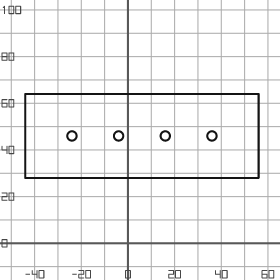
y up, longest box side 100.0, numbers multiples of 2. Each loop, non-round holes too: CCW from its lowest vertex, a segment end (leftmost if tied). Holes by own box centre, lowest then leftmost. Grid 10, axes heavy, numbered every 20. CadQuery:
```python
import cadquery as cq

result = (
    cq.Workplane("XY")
    .moveTo(-44.0, 28.0)
    .lineTo(56.0, 28.0)
    .lineTo(56.0, 64.0)
    .lineTo(-44.0, 64.0)
    .close()
    .moveTo(-24.0, 46.0)
    .circle(2.0)
    .moveTo(-4.0, 46.0)
    .circle(2.0)
    .moveTo(16.0, 46.0)
    .circle(2.0)
    .moveTo(36.0, 46.0)
    .circle(2.0)
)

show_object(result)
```